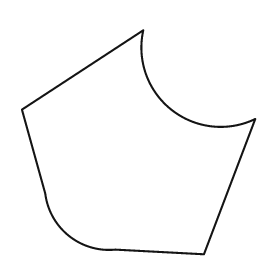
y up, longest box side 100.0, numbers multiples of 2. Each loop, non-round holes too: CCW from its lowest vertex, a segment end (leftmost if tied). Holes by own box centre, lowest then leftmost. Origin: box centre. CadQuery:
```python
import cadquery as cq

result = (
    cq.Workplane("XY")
    .moveTo(28.0, -48.0)
    .lineTo(50.0, 10.0)
    .threePointArc((14.0, 14.0), (2.0, 48.0))
    .lineTo(-50.0, 14.0)
    .lineTo(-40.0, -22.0)
    .threePointArc((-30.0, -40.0), (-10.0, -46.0))
    .close()
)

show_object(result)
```